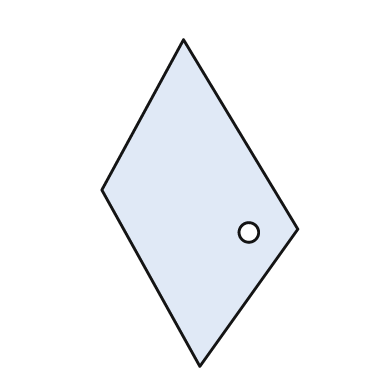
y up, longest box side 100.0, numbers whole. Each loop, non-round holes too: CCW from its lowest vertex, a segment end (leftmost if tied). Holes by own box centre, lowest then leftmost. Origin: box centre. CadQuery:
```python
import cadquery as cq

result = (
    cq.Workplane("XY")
    .moveTo(0.0, -50.0)
    .lineTo(30.0, -8.0)
    .lineTo(-5.0, 50.0)
    .lineTo(-30.0, 4.0)
    .close()
    .moveTo(15.0, -9.0)
    .circle(3.0)
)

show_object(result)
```